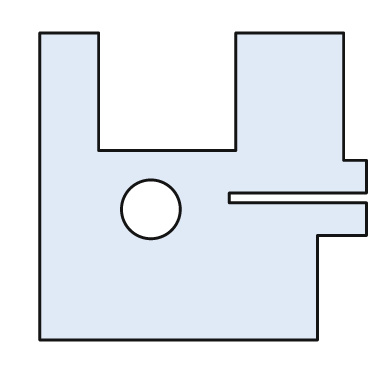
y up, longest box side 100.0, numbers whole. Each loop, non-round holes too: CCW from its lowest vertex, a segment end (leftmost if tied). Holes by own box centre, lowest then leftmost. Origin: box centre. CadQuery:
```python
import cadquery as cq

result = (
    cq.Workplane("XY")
    .moveTo(-50.0, -47.0)
    .lineTo(35.0, -47.0)
    .lineTo(35.0, -15.0)
    .lineTo(50.0, -15.0)
    .lineTo(50.0, -5.0)
    .lineTo(8.0, -5.0)
    .lineTo(8.0, -2.0)
    .lineTo(50.0, -2.0)
    .lineTo(50.0, 8.0)
    .lineTo(43.0, 8.0)
    .lineTo(43.0, 47.0)
    .lineTo(10.0, 47.0)
    .lineTo(10.0, 11.0)
    .lineTo(-32.0, 11.0)
    .lineTo(-32.0, 47.0)
    .lineTo(-50.0, 47.0)
    .close()
    .moveTo(-16.0, -7.0)
    .circle(9.0)
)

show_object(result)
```